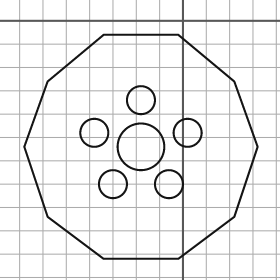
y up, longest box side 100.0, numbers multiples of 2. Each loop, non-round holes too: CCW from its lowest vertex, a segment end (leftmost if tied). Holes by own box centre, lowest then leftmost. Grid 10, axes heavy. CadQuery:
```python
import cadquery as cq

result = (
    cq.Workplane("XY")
    .moveTo(-34.0, -102.0)
    .lineTo(-2.0, -102.0)
    .lineTo(22.0, -84.0)
    .lineTo(32.0, -54.0)
    .lineTo(22.0, -26.0)
    .lineTo(-2.0, -6.0)
    .lineTo(-34.0, -6.0)
    .lineTo(-58.0, -26.0)
    .lineTo(-68.0, -54.0)
    .lineTo(-58.0, -84.0)
    .close()
    .moveTo(-30.0, -70.0)
    .circle(6.0)
    .moveTo(-6.0, -70.0)
    .circle(6.0)
    .moveTo(-18.0, -54.0)
    .circle(10.0)
    .moveTo(-38.0, -48.0)
    .circle(6.0)
    .moveTo(2.0, -48.0)
    .circle(6.0)
    .moveTo(-18.0, -34.0)
    .circle(6.0)
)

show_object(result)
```